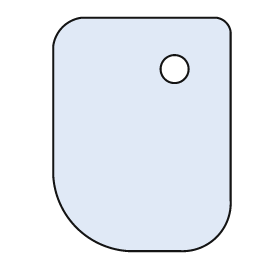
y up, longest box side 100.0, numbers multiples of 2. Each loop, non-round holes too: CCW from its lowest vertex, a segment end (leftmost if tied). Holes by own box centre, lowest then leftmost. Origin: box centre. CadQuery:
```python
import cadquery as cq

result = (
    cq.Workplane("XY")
    .moveTo(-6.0, -50.0)
    .lineTo(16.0, -50.0)
    .threePointArc((32.0, -44.0), (38.0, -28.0))
    .lineTo(38.0, 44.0)
    .threePointArc((36.0, 48.0), (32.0, 50.0))
    .lineTo(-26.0, 50.0)
    .threePointArc((-34.0, 46.0), (-38.0, 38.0))
    .lineTo(-38.0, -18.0)
    .threePointArc((-28.0, -40.0), (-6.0, -50.0))
    .close()
    .moveTo(14.0, 28.0)
    .circle(6.0)
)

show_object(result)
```